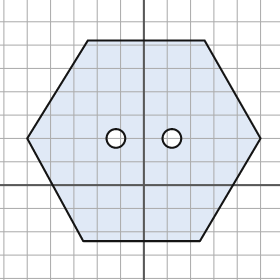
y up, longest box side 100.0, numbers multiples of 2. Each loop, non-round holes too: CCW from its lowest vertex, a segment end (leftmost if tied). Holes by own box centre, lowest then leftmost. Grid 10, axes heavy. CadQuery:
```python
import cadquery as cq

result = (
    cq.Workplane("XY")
    .moveTo(-26.0, -24.0)
    .lineTo(24.0, -24.0)
    .lineTo(50.0, 20.0)
    .lineTo(26.0, 62.0)
    .lineTo(-24.0, 62.0)
    .lineTo(-50.0, 20.0)
    .close()
    .moveTo(-12.0, 20.0)
    .circle(4.0)
    .moveTo(12.0, 20.0)
    .circle(4.0)
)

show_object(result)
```